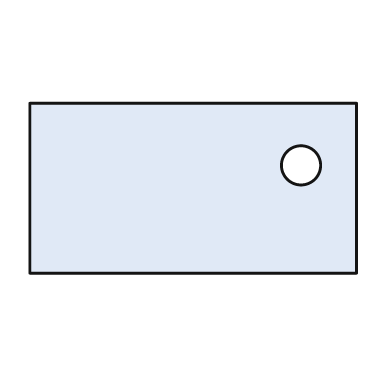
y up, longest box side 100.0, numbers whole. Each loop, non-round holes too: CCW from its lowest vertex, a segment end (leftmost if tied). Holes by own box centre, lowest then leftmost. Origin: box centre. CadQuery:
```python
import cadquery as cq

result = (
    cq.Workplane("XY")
    .moveTo(-50.0, -26.0)
    .lineTo(50.0, -26.0)
    .lineTo(50.0, 26.0)
    .lineTo(-50.0, 26.0)
    .close()
    .moveTo(33.0, 7.0)
    .circle(6.0)
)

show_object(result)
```